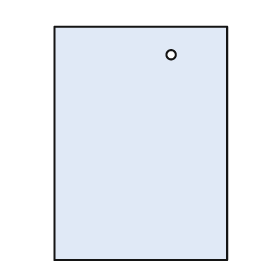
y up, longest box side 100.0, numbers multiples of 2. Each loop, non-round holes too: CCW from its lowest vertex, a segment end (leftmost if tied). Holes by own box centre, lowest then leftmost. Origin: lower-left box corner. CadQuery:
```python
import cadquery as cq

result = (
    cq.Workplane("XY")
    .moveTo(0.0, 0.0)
    .lineTo(74.0, 0.0)
    .lineTo(74.0, 100.0)
    .lineTo(0.0, 100.0)
    .close()
    .moveTo(50.0, 88.0)
    .circle(2.0)
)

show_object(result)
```